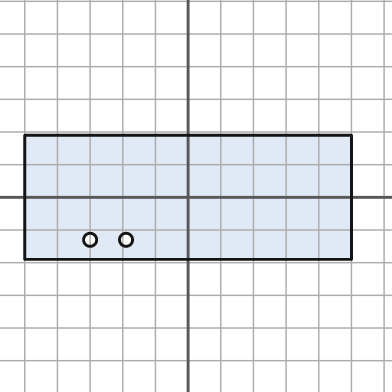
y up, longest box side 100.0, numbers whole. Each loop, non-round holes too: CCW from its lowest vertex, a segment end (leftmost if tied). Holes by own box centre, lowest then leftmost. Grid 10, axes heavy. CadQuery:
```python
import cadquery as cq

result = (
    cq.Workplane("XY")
    .moveTo(-50.0, -19.0)
    .lineTo(50.0, -19.0)
    .lineTo(50.0, 19.0)
    .lineTo(-50.0, 19.0)
    .close()
    .moveTo(-30.0, -13.0)
    .circle(2.0)
    .moveTo(-19.0, -13.0)
    .circle(2.0)
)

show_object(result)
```